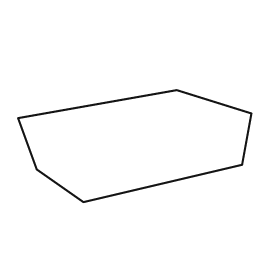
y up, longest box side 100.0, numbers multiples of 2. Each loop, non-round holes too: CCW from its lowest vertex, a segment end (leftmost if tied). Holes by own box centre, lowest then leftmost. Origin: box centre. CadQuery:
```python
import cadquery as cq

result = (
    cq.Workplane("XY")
    .moveTo(-22.0, -24.0)
    .lineTo(46.0, -8.0)
    .lineTo(50.0, 14.0)
    .lineTo(18.0, 24.0)
    .lineTo(-50.0, 12.0)
    .lineTo(-42.0, -10.0)
    .close()
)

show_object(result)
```